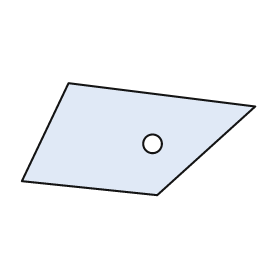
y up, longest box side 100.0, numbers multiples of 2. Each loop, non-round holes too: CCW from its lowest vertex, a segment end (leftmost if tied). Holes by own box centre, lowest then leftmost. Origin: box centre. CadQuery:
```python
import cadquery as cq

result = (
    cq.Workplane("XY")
    .moveTo(8.0, -24.0)
    .lineTo(50.0, 14.0)
    .lineTo(-30.0, 24.0)
    .lineTo(-50.0, -18.0)
    .close()
    .moveTo(6.0, -2.0)
    .circle(4.0)
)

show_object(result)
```